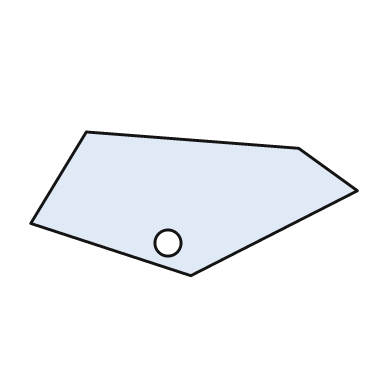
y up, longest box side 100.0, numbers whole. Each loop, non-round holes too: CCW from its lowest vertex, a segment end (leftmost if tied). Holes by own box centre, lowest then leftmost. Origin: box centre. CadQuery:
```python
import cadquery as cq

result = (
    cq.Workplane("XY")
    .moveTo(-1.0, -22.0)
    .lineTo(50.0, 4.0)
    .lineTo(32.0, 17.0)
    .lineTo(-33.0, 22.0)
    .lineTo(-50.0, -6.0)
    .close()
    .moveTo(-8.0, -12.0)
    .circle(4.0)
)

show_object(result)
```